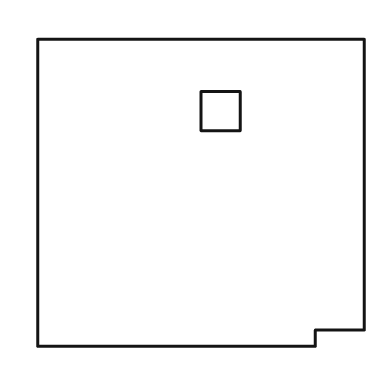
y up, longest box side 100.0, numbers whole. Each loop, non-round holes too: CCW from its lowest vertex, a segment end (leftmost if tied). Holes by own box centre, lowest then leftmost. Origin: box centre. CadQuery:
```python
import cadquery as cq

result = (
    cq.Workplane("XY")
    .moveTo(-50.0, -47.0)
    .lineTo(35.0, -47.0)
    .lineTo(35.0, -42.0)
    .lineTo(50.0, -42.0)
    .lineTo(50.0, 47.0)
    .lineTo(-50.0, 47.0)
    .close()
    .moveTo(0.0, 19.0)
    .lineTo(12.0, 19.0)
    .lineTo(12.0, 31.0)
    .lineTo(0.0, 31.0)
    .close()
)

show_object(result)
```